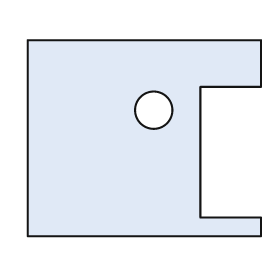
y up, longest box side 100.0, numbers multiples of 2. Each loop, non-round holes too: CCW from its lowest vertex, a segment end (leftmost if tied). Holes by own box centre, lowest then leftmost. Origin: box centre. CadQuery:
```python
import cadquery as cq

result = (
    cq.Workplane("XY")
    .moveTo(-50.0, -42.0)
    .lineTo(50.0, -42.0)
    .lineTo(50.0, -34.0)
    .lineTo(24.0, -34.0)
    .lineTo(24.0, 22.0)
    .lineTo(50.0, 22.0)
    .lineTo(50.0, 42.0)
    .lineTo(-50.0, 42.0)
    .close()
    .moveTo(4.0, 12.0)
    .circle(8.0)
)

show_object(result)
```